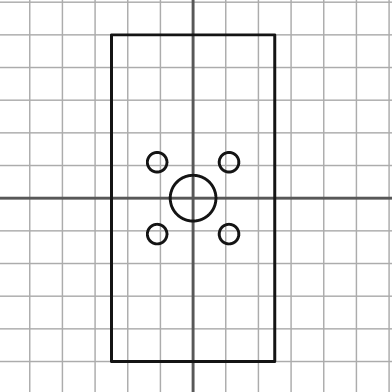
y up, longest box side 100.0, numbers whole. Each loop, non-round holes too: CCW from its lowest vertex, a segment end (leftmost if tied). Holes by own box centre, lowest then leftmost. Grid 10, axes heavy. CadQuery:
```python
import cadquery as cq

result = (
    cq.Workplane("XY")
    .moveTo(-25.0, -50.0)
    .lineTo(25.0, -50.0)
    .lineTo(25.0, 50.0)
    .lineTo(-25.0, 50.0)
    .close()
    .moveTo(-11.0, -11.0)
    .circle(3.0)
    .moveTo(11.0, -11.0)
    .circle(3.0)
    .moveTo(0.0, 0.0)
    .circle(7.0)
    .moveTo(-11.0, 11.0)
    .circle(3.0)
    .moveTo(11.0, 11.0)
    .circle(3.0)
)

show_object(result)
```